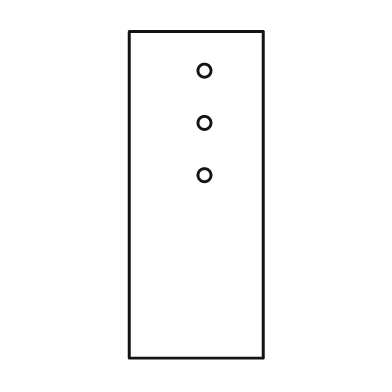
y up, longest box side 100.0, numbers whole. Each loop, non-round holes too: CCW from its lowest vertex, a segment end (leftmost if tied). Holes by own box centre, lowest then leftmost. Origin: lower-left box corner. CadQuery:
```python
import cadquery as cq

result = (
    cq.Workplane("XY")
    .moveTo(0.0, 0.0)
    .lineTo(41.0, 0.0)
    .lineTo(41.0, 100.0)
    .lineTo(0.0, 100.0)
    .close()
    .moveTo(23.0, 56.0)
    .circle(2.0)
    .moveTo(23.0, 72.0)
    .circle(2.0)
    .moveTo(23.0, 88.0)
    .circle(2.0)
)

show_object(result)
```